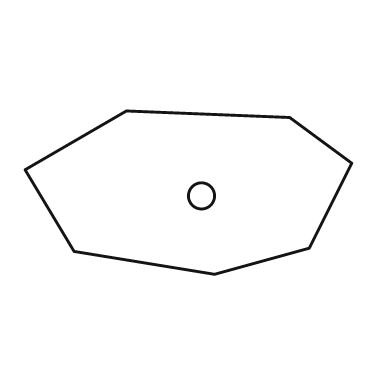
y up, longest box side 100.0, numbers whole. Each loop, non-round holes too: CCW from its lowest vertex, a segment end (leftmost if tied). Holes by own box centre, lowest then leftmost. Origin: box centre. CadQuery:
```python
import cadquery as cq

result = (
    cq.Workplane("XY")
    .moveTo(8.0, -25.0)
    .lineTo(37.0, -17.0)
    .lineTo(50.0, 9.0)
    .lineTo(31.0, 23.0)
    .lineTo(-19.0, 25.0)
    .lineTo(-50.0, 7.0)
    .lineTo(-35.0, -18.0)
    .close()
    .moveTo(4.0, -1.0)
    .circle(4.0)
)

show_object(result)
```